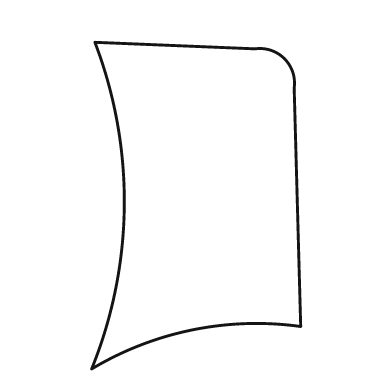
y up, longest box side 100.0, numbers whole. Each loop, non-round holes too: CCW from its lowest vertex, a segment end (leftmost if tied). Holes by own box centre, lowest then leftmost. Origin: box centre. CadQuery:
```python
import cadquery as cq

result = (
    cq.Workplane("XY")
    .moveTo(-32.0, -50.0)
    .threePointArc((-1.0, -38.0), (32.0, -37.0))
    .lineTo(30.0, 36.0)
    .threePointArc((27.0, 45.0), (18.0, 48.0))
    .lineTo(-31.0, 50.0)
    .threePointArc((-22.0, 0.0), (-32.0, -50.0))
    .close()
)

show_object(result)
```